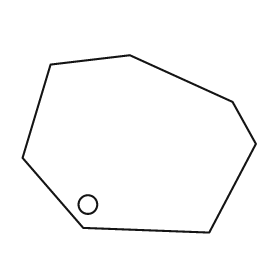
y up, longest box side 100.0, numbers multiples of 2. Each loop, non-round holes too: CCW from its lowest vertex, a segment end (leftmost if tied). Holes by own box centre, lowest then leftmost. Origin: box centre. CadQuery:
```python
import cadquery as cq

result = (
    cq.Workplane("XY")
    .moveTo(30.0, -38.0)
    .lineTo(50.0, 0.0)
    .lineTo(40.0, 18.0)
    .lineTo(-4.0, 38.0)
    .lineTo(-38.0, 34.0)
    .lineTo(-50.0, -6.0)
    .lineTo(-24.0, -36.0)
    .close()
    .moveTo(-22.0, -26.0)
    .circle(4.0)
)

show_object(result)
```